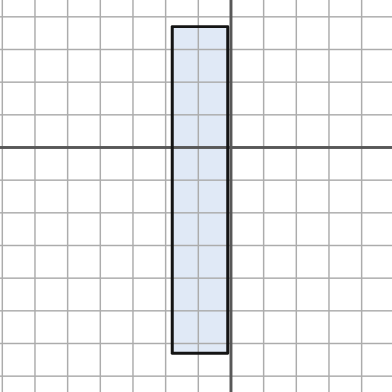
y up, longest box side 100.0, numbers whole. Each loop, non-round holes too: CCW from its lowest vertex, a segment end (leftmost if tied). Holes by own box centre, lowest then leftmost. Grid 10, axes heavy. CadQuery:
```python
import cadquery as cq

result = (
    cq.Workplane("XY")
    .moveTo(-18.0, -63.0)
    .lineTo(-1.0, -63.0)
    .lineTo(-1.0, 37.0)
    .lineTo(-18.0, 37.0)
    .close()
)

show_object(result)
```